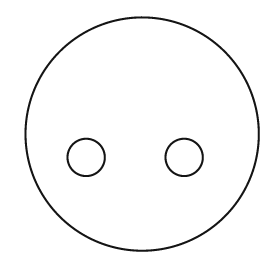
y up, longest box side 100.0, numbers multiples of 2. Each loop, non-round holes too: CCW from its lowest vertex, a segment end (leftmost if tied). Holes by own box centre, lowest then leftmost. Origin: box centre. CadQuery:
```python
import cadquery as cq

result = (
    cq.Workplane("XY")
    .moveTo(0.0, 0.0)
    .circle(50.0)
    .moveTo(-24.0, -10.0)
    .circle(8.0)
    .moveTo(18.0, -10.0)
    .circle(8.0)
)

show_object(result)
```